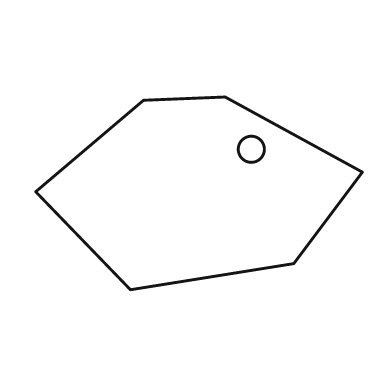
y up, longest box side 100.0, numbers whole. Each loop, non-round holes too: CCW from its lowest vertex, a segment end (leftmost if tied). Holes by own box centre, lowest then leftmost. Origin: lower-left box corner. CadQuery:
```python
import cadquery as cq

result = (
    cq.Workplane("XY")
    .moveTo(29.0, 0.0)
    .lineTo(79.0, 8.0)
    .lineTo(100.0, 36.0)
    .lineTo(58.0, 59.0)
    .lineTo(33.0, 58.0)
    .lineTo(0.0, 30.0)
    .close()
    .moveTo(66.0, 43.0)
    .circle(4.0)
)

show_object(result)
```